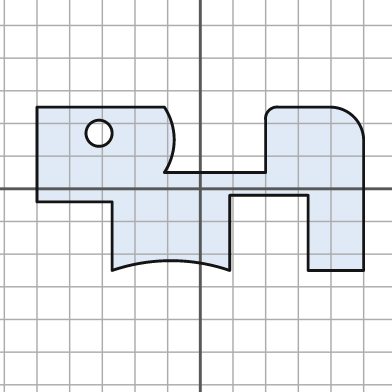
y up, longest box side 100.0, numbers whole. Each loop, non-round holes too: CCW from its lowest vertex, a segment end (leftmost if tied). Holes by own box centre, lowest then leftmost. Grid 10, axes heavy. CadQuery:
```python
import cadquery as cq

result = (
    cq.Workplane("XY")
    .moveTo(-27.0, -25.0)
    .threePointArc((-9.0, -22.0), (9.0, -25.0))
    .lineTo(9.0, -2.0)
    .lineTo(33.0, -2.0)
    .lineTo(33.0, -25.0)
    .lineTo(50.0, -25.0)
    .lineTo(50.0, 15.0)
    .threePointArc((47.0, 22.0), (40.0, 25.0))
    .lineTo(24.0, 25.0)
    .threePointArc((21.0, 24.0), (20.0, 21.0))
    .lineTo(20.0, 5.0)
    .lineTo(-11.0, 5.0)
    .threePointArc((-8.0, 15.0), (-11.0, 25.0))
    .lineTo(-50.0, 25.0)
    .lineTo(-50.0, -4.0)
    .lineTo(-27.0, -4.0)
    .close()
    .moveTo(-31.0, 17.0)
    .circle(4.0)
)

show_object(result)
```